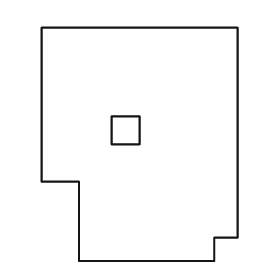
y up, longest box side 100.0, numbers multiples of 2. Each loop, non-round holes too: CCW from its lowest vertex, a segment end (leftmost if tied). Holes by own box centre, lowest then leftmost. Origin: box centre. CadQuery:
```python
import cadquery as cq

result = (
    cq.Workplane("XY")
    .moveTo(-26.0, -50.0)
    .lineTo(32.0, -50.0)
    .lineTo(32.0, -40.0)
    .lineTo(42.0, -40.0)
    .lineTo(42.0, 50.0)
    .lineTo(-42.0, 50.0)
    .lineTo(-42.0, -16.0)
    .lineTo(-26.0, -16.0)
    .close()
    .moveTo(-12.0, 0.0)
    .lineTo(0.0, 0.0)
    .lineTo(0.0, 12.0)
    .lineTo(-12.0, 12.0)
    .close()
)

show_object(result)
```